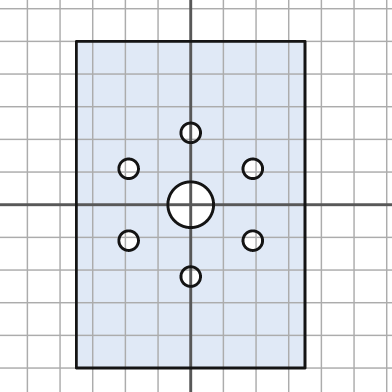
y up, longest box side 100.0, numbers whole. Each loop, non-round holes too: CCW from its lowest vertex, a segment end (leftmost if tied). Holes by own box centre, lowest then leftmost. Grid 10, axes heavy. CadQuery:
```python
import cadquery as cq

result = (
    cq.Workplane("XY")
    .moveTo(-35.0, -50.0)
    .lineTo(35.0, -50.0)
    .lineTo(35.0, 50.0)
    .lineTo(-35.0, 50.0)
    .close()
    .moveTo(0.0, -22.0)
    .circle(3.0)
    .moveTo(-19.0, -11.0)
    .circle(3.0)
    .moveTo(19.0, -11.0)
    .circle(3.0)
    .moveTo(0.0, 0.0)
    .circle(7.0)
    .moveTo(-19.0, 11.0)
    .circle(3.0)
    .moveTo(19.0, 11.0)
    .circle(3.0)
    .moveTo(0.0, 22.0)
    .circle(3.0)
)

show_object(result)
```